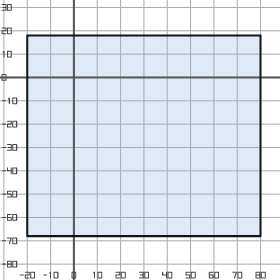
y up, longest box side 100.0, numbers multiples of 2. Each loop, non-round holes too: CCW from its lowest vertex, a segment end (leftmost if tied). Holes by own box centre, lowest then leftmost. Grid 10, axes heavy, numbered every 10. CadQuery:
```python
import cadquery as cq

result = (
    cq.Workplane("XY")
    .moveTo(-20.0, -68.0)
    .lineTo(80.0, -68.0)
    .lineTo(80.0, 18.0)
    .lineTo(-20.0, 18.0)
    .close()
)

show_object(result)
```